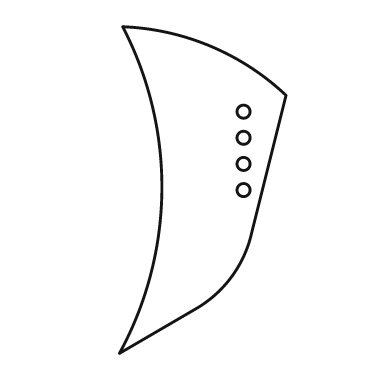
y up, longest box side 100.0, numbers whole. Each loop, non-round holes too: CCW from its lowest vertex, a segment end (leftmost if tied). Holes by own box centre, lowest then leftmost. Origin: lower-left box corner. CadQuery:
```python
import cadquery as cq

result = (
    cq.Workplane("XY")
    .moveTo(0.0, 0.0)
    .lineTo(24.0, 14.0)
    .threePointArc((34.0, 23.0), (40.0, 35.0))
    .lineTo(51.0, 79.0)
    .threePointArc((28.0, 94.0), (1.0, 100.0))
    .threePointArc((13.0, 50.0), (0.0, 0.0))
    .close()
    .moveTo(38.0, 50.0)
    .circle(2.0)
    .moveTo(38.0, 58.0)
    .circle(2.0)
    .moveTo(38.0, 66.0)
    .circle(2.0)
    .moveTo(38.0, 74.0)
    .circle(2.0)
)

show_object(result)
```